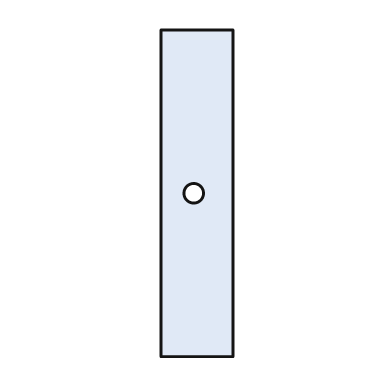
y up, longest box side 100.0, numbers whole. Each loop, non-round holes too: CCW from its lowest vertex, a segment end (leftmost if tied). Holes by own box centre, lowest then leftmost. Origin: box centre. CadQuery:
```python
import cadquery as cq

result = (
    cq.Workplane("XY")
    .moveTo(-11.0, -50.0)
    .lineTo(11.0, -50.0)
    .lineTo(11.0, 50.0)
    .lineTo(-11.0, 50.0)
    .close()
    .moveTo(-1.0, 0.0)
    .circle(3.0)
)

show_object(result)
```